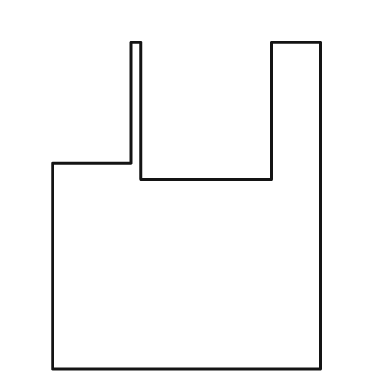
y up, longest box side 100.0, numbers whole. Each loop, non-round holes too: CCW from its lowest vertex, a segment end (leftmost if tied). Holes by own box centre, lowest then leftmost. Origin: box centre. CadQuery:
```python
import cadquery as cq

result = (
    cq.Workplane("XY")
    .moveTo(-41.0, -50.0)
    .lineTo(41.0, -50.0)
    .lineTo(41.0, 50.0)
    .lineTo(26.0, 50.0)
    .lineTo(26.0, 8.0)
    .lineTo(-14.0, 8.0)
    .lineTo(-14.0, 50.0)
    .lineTo(-17.0, 50.0)
    .lineTo(-17.0, 13.0)
    .lineTo(-41.0, 13.0)
    .close()
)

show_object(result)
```